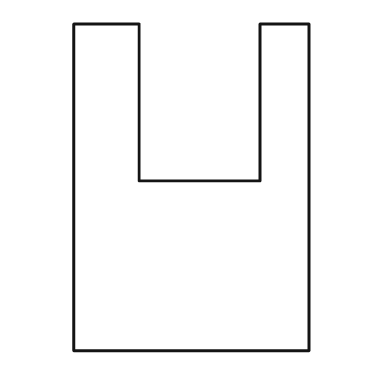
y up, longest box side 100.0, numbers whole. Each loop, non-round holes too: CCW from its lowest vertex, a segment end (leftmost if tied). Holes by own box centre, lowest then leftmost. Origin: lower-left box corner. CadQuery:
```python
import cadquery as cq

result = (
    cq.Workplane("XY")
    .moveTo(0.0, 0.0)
    .lineTo(72.0, 0.0)
    .lineTo(72.0, 100.0)
    .lineTo(57.0, 100.0)
    .lineTo(57.0, 52.0)
    .lineTo(20.0, 52.0)
    .lineTo(20.0, 100.0)
    .lineTo(0.0, 100.0)
    .close()
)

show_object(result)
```